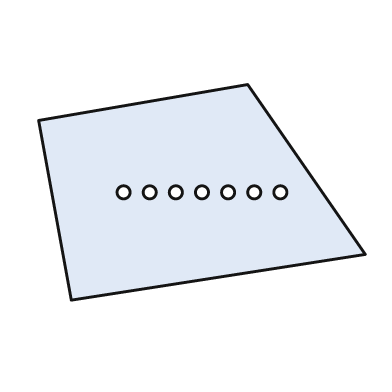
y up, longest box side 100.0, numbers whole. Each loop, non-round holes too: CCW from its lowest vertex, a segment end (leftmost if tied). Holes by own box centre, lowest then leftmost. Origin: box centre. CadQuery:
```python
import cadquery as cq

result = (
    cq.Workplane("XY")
    .moveTo(-40.0, -33.0)
    .lineTo(50.0, -19.0)
    .lineTo(14.0, 33.0)
    .lineTo(-50.0, 22.0)
    .close()
    .moveTo(-24.0, 0.0)
    .circle(2.0)
    .moveTo(-16.0, 0.0)
    .circle(2.0)
    .moveTo(-8.0, 0.0)
    .circle(2.0)
    .moveTo(0.0, 0.0)
    .circle(2.0)
    .moveTo(8.0, 0.0)
    .circle(2.0)
    .moveTo(16.0, 0.0)
    .circle(2.0)
    .moveTo(24.0, 0.0)
    .circle(2.0)
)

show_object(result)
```